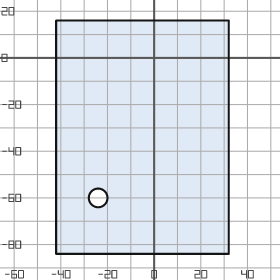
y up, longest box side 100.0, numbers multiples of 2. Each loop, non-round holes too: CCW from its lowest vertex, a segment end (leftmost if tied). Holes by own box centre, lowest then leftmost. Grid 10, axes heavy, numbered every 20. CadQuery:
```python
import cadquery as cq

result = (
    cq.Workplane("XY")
    .moveTo(-42.0, -84.0)
    .lineTo(32.0, -84.0)
    .lineTo(32.0, 16.0)
    .lineTo(-42.0, 16.0)
    .close()
    .moveTo(-24.0, -60.0)
    .circle(4.0)
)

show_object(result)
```